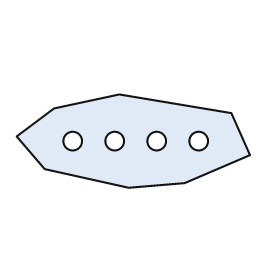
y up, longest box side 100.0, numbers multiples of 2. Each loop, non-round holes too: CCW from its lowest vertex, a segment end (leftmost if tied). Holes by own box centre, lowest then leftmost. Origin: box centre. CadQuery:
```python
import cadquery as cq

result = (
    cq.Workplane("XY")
    .moveTo(-2.0, -20.0)
    .lineTo(22.0, -18.0)
    .lineTo(50.0, -6.0)
    .lineTo(42.0, 12.0)
    .lineTo(-6.0, 20.0)
    .lineTo(-34.0, 14.0)
    .lineTo(-50.0, 2.0)
    .lineTo(-38.0, -12.0)
    .close()
    .moveTo(-26.0, 0.0)
    .circle(4.0)
    .moveTo(-8.0, 0.0)
    .circle(4.0)
    .moveTo(10.0, 0.0)
    .circle(4.0)
    .moveTo(28.0, 0.0)
    .circle(4.0)
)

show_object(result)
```